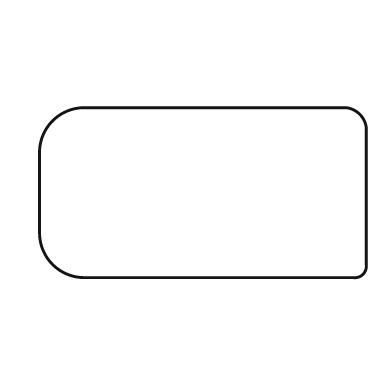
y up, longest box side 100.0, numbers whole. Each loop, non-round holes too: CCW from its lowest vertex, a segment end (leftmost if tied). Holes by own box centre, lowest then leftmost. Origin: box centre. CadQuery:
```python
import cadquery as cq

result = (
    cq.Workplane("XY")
    .moveTo(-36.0, -26.0)
    .lineTo(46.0, -26.0)
    .threePointArc((49.0, -25.0), (50.0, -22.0))
    .lineTo(50.0, 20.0)
    .threePointArc((48.0, 24.0), (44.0, 26.0))
    .lineTo(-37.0, 26.0)
    .threePointArc((-46.0, 22.0), (-50.0, 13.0))
    .lineTo(-50.0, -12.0)
    .threePointArc((-46.0, -22.0), (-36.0, -26.0))
    .close()
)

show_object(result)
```